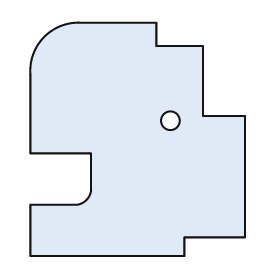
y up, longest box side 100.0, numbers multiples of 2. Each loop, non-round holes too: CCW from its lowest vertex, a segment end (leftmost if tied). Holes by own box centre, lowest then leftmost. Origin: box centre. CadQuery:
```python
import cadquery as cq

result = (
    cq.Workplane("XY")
    .moveTo(-46.0, -50.0)
    .lineTo(20.0, -50.0)
    .lineTo(20.0, -42.0)
    .lineTo(46.0, -42.0)
    .lineTo(46.0, 10.0)
    .lineTo(28.0, 10.0)
    .lineTo(28.0, 40.0)
    .lineTo(8.0, 40.0)
    .lineTo(8.0, 50.0)
    .lineTo(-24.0, 50.0)
    .threePointArc((-40.0, 44.0), (-46.0, 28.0))
    .lineTo(-46.0, -6.0)
    .lineTo(-20.0, -6.0)
    .lineTo(-20.0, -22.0)
    .threePointArc((-22.0, -26.0), (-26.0, -28.0))
    .lineTo(-46.0, -28.0)
    .close()
    .moveTo(14.0, 8.0)
    .circle(4.0)
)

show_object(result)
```